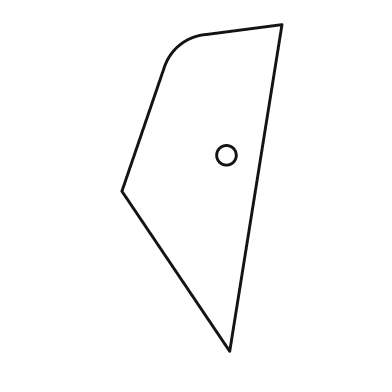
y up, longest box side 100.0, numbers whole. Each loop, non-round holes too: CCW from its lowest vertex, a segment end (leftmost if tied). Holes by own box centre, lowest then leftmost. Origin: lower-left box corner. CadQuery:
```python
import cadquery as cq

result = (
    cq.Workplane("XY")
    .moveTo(33.0, 0.0)
    .lineTo(49.0, 100.0)
    .lineTo(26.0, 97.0)
    .threePointArc((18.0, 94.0), (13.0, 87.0))
    .lineTo(0.0, 49.0)
    .close()
    .moveTo(32.0, 60.0)
    .circle(3.0)
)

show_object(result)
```